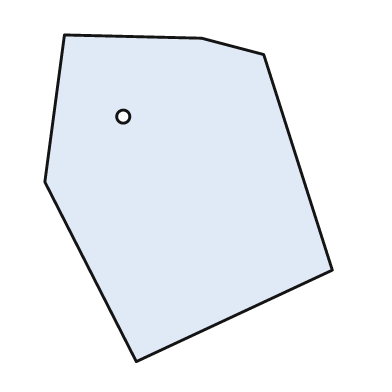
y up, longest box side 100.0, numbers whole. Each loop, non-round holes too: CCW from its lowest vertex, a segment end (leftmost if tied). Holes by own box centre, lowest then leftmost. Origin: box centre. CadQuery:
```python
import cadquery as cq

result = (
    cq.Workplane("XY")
    .moveTo(-16.0, -50.0)
    .lineTo(44.0, -22.0)
    .lineTo(23.0, 44.0)
    .lineTo(4.0, 49.0)
    .lineTo(-38.0, 50.0)
    .lineTo(-44.0, 5.0)
    .close()
    .moveTo(-20.0, 25.0)
    .circle(2.0)
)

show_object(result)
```